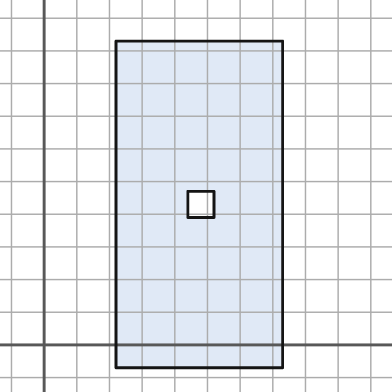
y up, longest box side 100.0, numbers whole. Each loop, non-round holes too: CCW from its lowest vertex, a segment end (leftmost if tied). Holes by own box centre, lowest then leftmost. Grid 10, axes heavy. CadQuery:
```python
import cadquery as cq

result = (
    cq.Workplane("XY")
    .moveTo(22.0, -7.0)
    .lineTo(73.0, -7.0)
    .lineTo(73.0, 93.0)
    .lineTo(22.0, 93.0)
    .close()
    .moveTo(44.0, 39.0)
    .lineTo(52.0, 39.0)
    .lineTo(52.0, 47.0)
    .lineTo(44.0, 47.0)
    .close()
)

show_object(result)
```